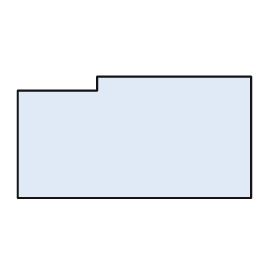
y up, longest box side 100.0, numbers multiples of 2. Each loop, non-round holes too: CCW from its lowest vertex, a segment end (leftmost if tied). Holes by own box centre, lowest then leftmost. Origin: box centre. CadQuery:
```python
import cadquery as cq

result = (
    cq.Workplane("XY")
    .moveTo(-50.0, -26.0)
    .lineTo(50.0, -26.0)
    .lineTo(50.0, 26.0)
    .lineTo(-16.0, 26.0)
    .lineTo(-16.0, 20.0)
    .lineTo(-50.0, 20.0)
    .close()
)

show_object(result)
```